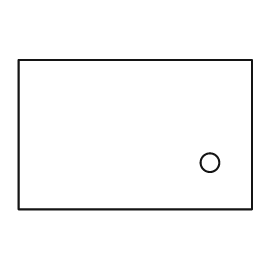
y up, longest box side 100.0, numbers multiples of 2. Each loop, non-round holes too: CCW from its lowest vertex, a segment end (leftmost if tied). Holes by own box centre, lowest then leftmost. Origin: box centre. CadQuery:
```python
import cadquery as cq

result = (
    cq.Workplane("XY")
    .moveTo(-50.0, -32.0)
    .lineTo(50.0, -32.0)
    .lineTo(50.0, 32.0)
    .lineTo(-50.0, 32.0)
    .close()
    .moveTo(32.0, -12.0)
    .circle(4.0)
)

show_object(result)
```